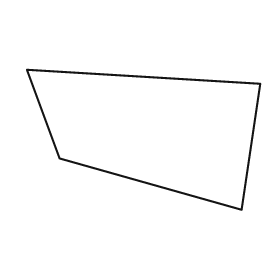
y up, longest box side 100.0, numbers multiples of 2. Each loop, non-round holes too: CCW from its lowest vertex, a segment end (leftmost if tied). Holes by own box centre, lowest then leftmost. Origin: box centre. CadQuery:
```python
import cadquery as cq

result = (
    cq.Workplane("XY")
    .moveTo(42.0, -30.0)
    .lineTo(50.0, 24.0)
    .lineTo(-50.0, 30.0)
    .lineTo(-36.0, -8.0)
    .close()
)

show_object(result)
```